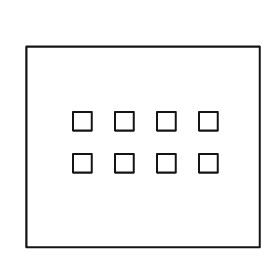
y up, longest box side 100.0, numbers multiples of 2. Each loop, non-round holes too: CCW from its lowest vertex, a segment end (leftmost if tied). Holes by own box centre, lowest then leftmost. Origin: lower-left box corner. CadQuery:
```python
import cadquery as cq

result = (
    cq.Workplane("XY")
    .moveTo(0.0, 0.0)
    .lineTo(100.0, 0.0)
    .lineTo(100.0, 86.0)
    .lineTo(0.0, 86.0)
    .close()
    .moveTo(20.0, 32.0)
    .lineTo(28.0, 32.0)
    .lineTo(28.0, 40.0)
    .lineTo(20.0, 40.0)
    .close()
    .moveTo(38.0, 32.0)
    .lineTo(46.0, 32.0)
    .lineTo(46.0, 40.0)
    .lineTo(38.0, 40.0)
    .close()
    .moveTo(56.0, 32.0)
    .lineTo(64.0, 32.0)
    .lineTo(64.0, 40.0)
    .lineTo(56.0, 40.0)
    .close()
    .moveTo(74.0, 32.0)
    .lineTo(82.0, 32.0)
    .lineTo(82.0, 40.0)
    .lineTo(74.0, 40.0)
    .close()
    .moveTo(20.0, 50.0)
    .lineTo(28.0, 50.0)
    .lineTo(28.0, 58.0)
    .lineTo(20.0, 58.0)
    .close()
    .moveTo(38.0, 50.0)
    .lineTo(46.0, 50.0)
    .lineTo(46.0, 58.0)
    .lineTo(38.0, 58.0)
    .close()
    .moveTo(56.0, 50.0)
    .lineTo(64.0, 50.0)
    .lineTo(64.0, 58.0)
    .lineTo(56.0, 58.0)
    .close()
    .moveTo(74.0, 50.0)
    .lineTo(82.0, 50.0)
    .lineTo(82.0, 58.0)
    .lineTo(74.0, 58.0)
    .close()
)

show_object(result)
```